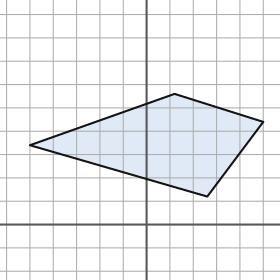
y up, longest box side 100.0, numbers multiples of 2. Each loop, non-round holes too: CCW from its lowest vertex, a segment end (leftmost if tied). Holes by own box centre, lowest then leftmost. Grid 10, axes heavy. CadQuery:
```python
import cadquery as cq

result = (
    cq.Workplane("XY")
    .moveTo(26.0, 12.0)
    .lineTo(50.0, 44.0)
    .lineTo(12.0, 56.0)
    .lineTo(-50.0, 34.0)
    .close()
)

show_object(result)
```